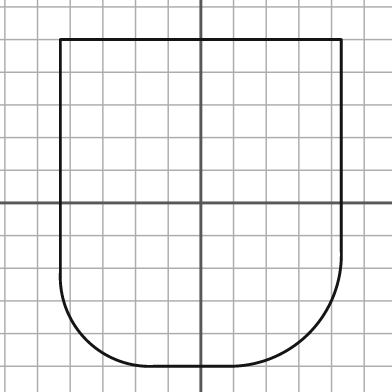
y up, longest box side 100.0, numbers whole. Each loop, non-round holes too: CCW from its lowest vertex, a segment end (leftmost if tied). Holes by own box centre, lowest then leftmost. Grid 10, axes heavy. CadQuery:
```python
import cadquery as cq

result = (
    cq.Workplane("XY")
    .moveTo(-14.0, -50.0)
    .lineTo(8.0, -50.0)
    .threePointArc((33.0, -40.0), (43.0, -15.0))
    .lineTo(43.0, 50.0)
    .lineTo(-43.0, 50.0)
    .lineTo(-43.0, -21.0)
    .threePointArc((-35.0, -42.0), (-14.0, -50.0))
    .close()
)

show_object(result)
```